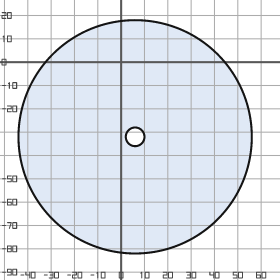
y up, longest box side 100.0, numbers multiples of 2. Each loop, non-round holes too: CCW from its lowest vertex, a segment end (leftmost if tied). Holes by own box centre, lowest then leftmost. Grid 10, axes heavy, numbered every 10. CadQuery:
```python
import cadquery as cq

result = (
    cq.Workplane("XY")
    .moveTo(6.0, -32.0)
    .circle(50.0)
    .moveTo(6.0, -32.0)
    .circle(4.0)
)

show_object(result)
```